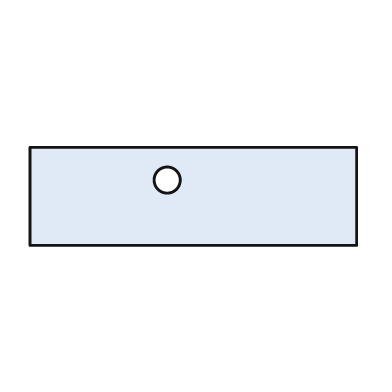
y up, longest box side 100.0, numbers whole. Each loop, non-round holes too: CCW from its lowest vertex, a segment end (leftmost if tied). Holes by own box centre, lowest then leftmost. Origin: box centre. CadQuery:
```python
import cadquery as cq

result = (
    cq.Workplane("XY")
    .moveTo(-50.0, -15.0)
    .lineTo(50.0, -15.0)
    .lineTo(50.0, 15.0)
    .lineTo(-50.0, 15.0)
    .close()
    .moveTo(-8.0, 5.0)
    .circle(4.0)
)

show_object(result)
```